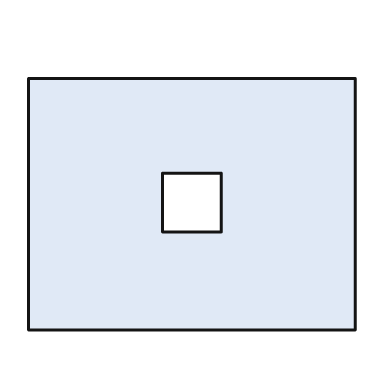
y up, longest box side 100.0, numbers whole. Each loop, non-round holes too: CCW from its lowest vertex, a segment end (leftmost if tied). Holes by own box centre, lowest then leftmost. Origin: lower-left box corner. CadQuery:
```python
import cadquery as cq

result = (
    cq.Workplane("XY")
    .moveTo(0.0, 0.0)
    .lineTo(100.0, 0.0)
    .lineTo(100.0, 77.0)
    .lineTo(0.0, 77.0)
    .close()
    .moveTo(41.0, 30.0)
    .lineTo(59.0, 30.0)
    .lineTo(59.0, 48.0)
    .lineTo(41.0, 48.0)
    .close()
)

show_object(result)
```